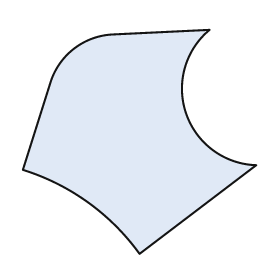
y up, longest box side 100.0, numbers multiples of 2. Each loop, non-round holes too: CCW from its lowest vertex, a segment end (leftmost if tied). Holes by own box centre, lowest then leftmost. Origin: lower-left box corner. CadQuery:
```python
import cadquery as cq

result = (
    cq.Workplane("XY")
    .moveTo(50.0, 0.0)
    .lineTo(100.0, 38.0)
    .threePointArc((70.0, 60.0), (80.0, 96.0))
    .lineTo(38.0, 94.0)
    .threePointArc((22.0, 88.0), (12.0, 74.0))
    .lineTo(0.0, 36.0)
    .threePointArc((28.0, 22.0), (50.0, 0.0))
    .close()
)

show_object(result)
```